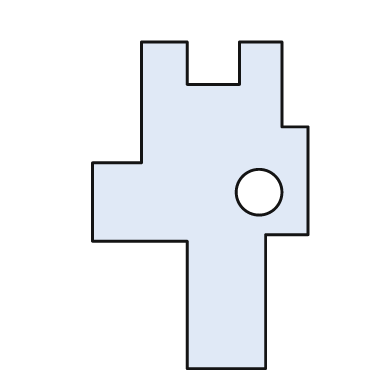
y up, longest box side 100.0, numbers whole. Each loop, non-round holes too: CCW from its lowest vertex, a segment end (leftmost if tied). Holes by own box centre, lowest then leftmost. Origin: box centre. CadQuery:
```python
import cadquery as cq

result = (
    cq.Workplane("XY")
    .moveTo(-4.0, -50.0)
    .lineTo(20.0, -50.0)
    .lineTo(20.0, -9.0)
    .lineTo(33.0, -9.0)
    .lineTo(33.0, 24.0)
    .lineTo(25.0, 24.0)
    .lineTo(25.0, 50.0)
    .lineTo(12.0, 50.0)
    .lineTo(12.0, 37.0)
    .lineTo(-4.0, 37.0)
    .lineTo(-4.0, 50.0)
    .lineTo(-18.0, 50.0)
    .lineTo(-18.0, 13.0)
    .lineTo(-33.0, 13.0)
    .lineTo(-33.0, -11.0)
    .lineTo(-4.0, -11.0)
    .close()
    .moveTo(18.0, 4.0)
    .circle(7.0)
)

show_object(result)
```